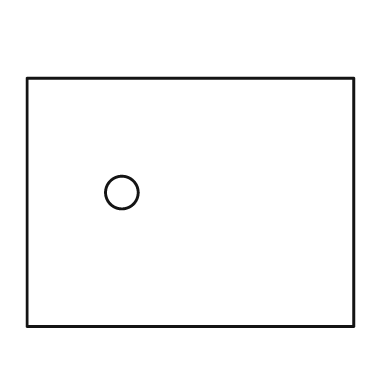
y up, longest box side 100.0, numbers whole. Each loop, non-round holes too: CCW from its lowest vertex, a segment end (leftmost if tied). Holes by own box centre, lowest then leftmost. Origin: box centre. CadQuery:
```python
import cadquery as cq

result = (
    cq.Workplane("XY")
    .moveTo(-50.0, -38.0)
    .lineTo(50.0, -38.0)
    .lineTo(50.0, 38.0)
    .lineTo(-50.0, 38.0)
    .close()
    .moveTo(-21.0, 3.0)
    .circle(5.0)
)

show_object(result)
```